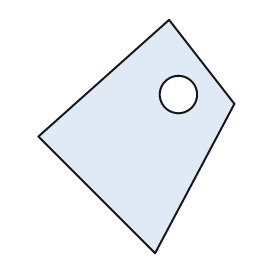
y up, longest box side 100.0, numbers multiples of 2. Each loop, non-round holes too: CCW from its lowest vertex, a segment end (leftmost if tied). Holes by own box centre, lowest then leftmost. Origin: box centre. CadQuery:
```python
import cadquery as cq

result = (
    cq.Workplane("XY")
    .moveTo(8.0, -50.0)
    .lineTo(42.0, 14.0)
    .lineTo(14.0, 50.0)
    .lineTo(-42.0, 0.0)
    .close()
    .moveTo(18.0, 18.0)
    .circle(8.0)
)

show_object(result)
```